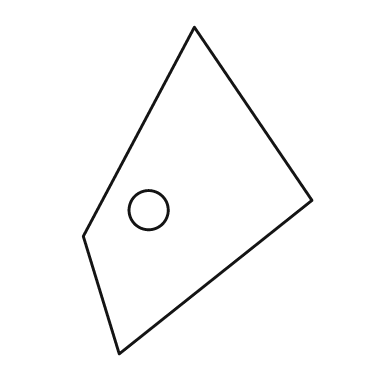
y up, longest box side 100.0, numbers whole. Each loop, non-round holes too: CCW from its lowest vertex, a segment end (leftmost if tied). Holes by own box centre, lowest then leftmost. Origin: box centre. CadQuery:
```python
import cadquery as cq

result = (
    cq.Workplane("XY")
    .moveTo(-24.0, -50.0)
    .lineTo(35.0, -3.0)
    .lineTo(-1.0, 50.0)
    .lineTo(-35.0, -14.0)
    .close()
    .moveTo(-15.0, -6.0)
    .circle(6.0)
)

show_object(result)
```